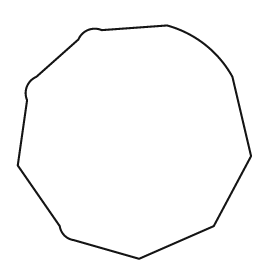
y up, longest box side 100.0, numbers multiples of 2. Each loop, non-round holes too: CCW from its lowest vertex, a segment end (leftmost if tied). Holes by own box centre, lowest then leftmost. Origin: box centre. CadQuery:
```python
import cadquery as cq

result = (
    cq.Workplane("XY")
    .moveTo(2.0, -50.0)
    .lineTo(34.0, -36.0)
    .lineTo(50.0, -6.0)
    .lineTo(42.0, 28.0)
    .threePointArc((30.0, 42.0), (14.0, 50.0))
    .lineTo(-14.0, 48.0)
    .threePointArc((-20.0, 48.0), (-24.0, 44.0))
    .lineTo(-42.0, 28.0)
    .threePointArc((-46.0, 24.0), (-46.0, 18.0))
    .lineTo(-50.0, -10.0)
    .lineTo(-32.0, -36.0)
    .threePointArc((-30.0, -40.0), (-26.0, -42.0))
    .close()
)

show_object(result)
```